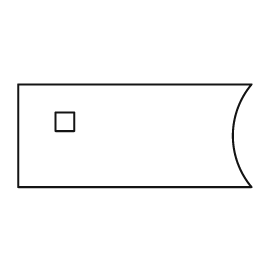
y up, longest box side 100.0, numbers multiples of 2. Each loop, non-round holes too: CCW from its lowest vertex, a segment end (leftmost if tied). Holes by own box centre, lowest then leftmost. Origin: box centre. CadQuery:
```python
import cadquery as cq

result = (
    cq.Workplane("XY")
    .moveTo(-50.0, -22.0)
    .lineTo(50.0, -22.0)
    .threePointArc((42.0, 0.0), (50.0, 22.0))
    .lineTo(-50.0, 22.0)
    .close()
    .moveTo(-34.0, 2.0)
    .lineTo(-26.0, 2.0)
    .lineTo(-26.0, 10.0)
    .lineTo(-34.0, 10.0)
    .close()
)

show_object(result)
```